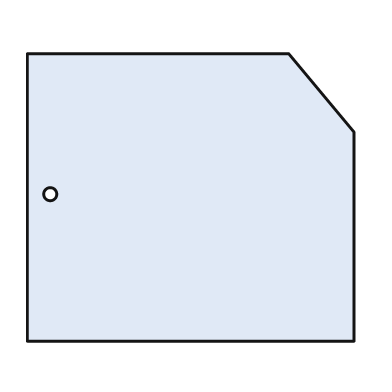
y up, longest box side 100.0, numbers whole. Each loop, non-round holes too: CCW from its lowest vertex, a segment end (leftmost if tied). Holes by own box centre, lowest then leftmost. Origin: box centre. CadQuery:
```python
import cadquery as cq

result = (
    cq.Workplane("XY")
    .moveTo(-50.0, -44.0)
    .lineTo(50.0, -44.0)
    .lineTo(50.0, 20.0)
    .lineTo(30.0, 44.0)
    .lineTo(-50.0, 44.0)
    .close()
    .moveTo(-43.0, 1.0)
    .circle(2.0)
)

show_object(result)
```